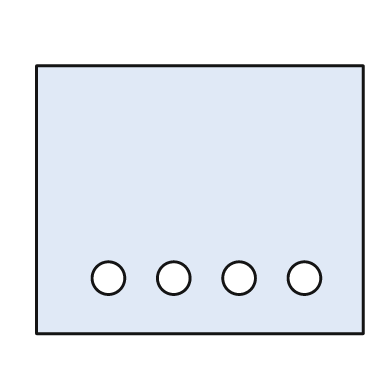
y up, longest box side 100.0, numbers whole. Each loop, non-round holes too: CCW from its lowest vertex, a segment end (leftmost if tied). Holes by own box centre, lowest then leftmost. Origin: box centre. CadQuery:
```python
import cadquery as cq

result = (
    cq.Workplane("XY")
    .moveTo(-50.0, -41.0)
    .lineTo(50.0, -41.0)
    .lineTo(50.0, 41.0)
    .lineTo(-50.0, 41.0)
    .close()
    .moveTo(-28.0, -24.0)
    .circle(5.0)
    .moveTo(-8.0, -24.0)
    .circle(5.0)
    .moveTo(12.0, -24.0)
    .circle(5.0)
    .moveTo(32.0, -24.0)
    .circle(5.0)
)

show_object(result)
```